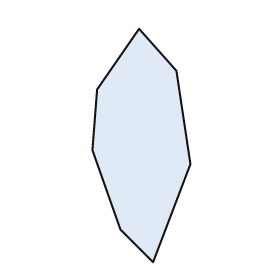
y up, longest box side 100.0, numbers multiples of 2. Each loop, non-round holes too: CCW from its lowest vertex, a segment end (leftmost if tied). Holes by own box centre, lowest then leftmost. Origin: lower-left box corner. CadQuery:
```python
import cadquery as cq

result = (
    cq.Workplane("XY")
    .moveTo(26.0, 0.0)
    .lineTo(42.0, 42.0)
    .lineTo(36.0, 82.0)
    .lineTo(20.0, 100.0)
    .lineTo(2.0, 74.0)
    .lineTo(0.0, 48.0)
    .lineTo(12.0, 14.0)
    .close()
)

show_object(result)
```